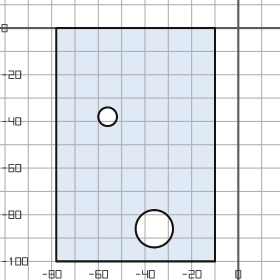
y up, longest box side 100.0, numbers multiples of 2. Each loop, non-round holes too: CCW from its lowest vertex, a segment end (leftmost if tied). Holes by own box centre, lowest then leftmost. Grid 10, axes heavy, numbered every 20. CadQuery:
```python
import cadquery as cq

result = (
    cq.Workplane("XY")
    .moveTo(-78.0, -100.0)
    .lineTo(-10.0, -100.0)
    .lineTo(-10.0, 0.0)
    .lineTo(-78.0, 0.0)
    .close()
    .moveTo(-36.0, -86.0)
    .circle(8.0)
    .moveTo(-56.0, -38.0)
    .circle(4.0)
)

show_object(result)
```